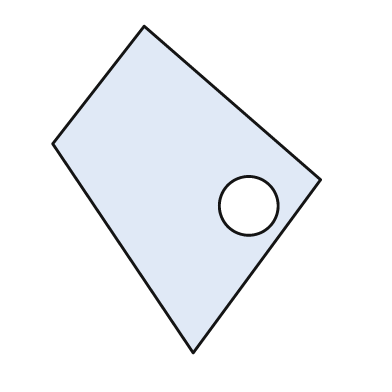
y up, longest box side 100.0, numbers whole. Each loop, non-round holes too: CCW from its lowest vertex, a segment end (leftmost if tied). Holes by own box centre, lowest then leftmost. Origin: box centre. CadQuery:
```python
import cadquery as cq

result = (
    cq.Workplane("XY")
    .moveTo(2.0, -50.0)
    .lineTo(41.0, 3.0)
    .lineTo(-13.0, 50.0)
    .lineTo(-41.0, 14.0)
    .close()
    .moveTo(19.0, -5.0)
    .circle(9.0)
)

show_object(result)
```